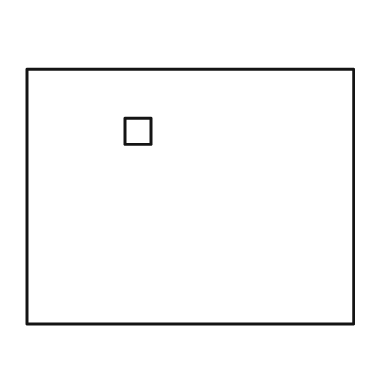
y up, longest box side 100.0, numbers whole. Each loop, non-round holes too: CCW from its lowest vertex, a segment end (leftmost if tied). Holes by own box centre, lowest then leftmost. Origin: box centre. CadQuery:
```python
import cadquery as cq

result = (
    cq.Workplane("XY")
    .moveTo(-50.0, -39.0)
    .lineTo(50.0, -39.0)
    .lineTo(50.0, 39.0)
    .lineTo(-50.0, 39.0)
    .close()
    .moveTo(-20.0, 16.0)
    .lineTo(-12.0, 16.0)
    .lineTo(-12.0, 24.0)
    .lineTo(-20.0, 24.0)
    .close()
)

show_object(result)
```